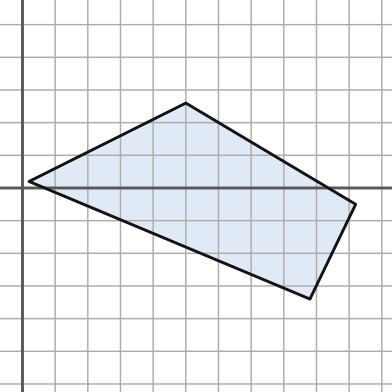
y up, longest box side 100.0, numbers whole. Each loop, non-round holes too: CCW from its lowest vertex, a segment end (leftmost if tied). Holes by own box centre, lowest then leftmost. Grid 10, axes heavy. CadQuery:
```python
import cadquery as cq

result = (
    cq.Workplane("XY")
    .moveTo(88.0, -34.0)
    .lineTo(102.0, -5.0)
    .lineTo(50.0, 26.0)
    .lineTo(2.0, 2.0)
    .close()
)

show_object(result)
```